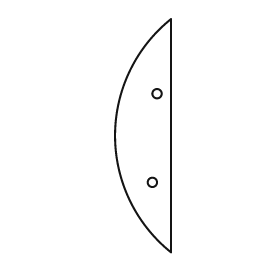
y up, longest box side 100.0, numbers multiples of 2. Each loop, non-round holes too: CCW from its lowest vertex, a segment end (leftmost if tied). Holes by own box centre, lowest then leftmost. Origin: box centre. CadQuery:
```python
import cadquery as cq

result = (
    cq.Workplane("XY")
    .moveTo(12.0, -50.0)
    .lineTo(12.0, 50.0)
    .threePointArc((-12.0, 0.0), (12.0, -50.0))
    .close()
    .moveTo(4.0, -20.0)
    .circle(2.0)
    .moveTo(6.0, 18.0)
    .circle(2.0)
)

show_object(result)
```